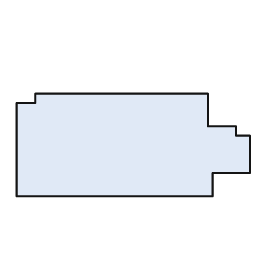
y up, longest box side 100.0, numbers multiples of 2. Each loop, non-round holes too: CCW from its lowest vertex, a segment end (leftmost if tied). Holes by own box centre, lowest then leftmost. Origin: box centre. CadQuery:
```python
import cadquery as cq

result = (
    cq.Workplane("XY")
    .moveTo(-50.0, -22.0)
    .lineTo(34.0, -22.0)
    .lineTo(34.0, -12.0)
    .lineTo(50.0, -12.0)
    .lineTo(50.0, 4.0)
    .lineTo(44.0, 4.0)
    .lineTo(44.0, 8.0)
    .lineTo(32.0, 8.0)
    .lineTo(32.0, 22.0)
    .lineTo(-42.0, 22.0)
    .lineTo(-42.0, 18.0)
    .lineTo(-50.0, 18.0)
    .close()
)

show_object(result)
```